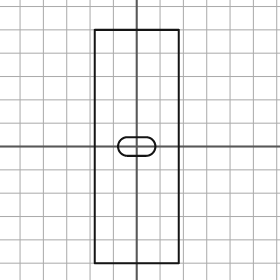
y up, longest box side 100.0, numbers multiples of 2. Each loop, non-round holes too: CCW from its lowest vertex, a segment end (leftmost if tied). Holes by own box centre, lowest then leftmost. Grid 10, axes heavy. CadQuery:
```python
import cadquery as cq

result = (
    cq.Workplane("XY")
    .moveTo(-18.0, -50.0)
    .lineTo(18.0, -50.0)
    .lineTo(18.0, 50.0)
    .lineTo(-18.0, 50.0)
    .close()
    .moveTo(-4.0, -4.0)
    .lineTo(4.0, -4.0)
    .threePointArc((8.0, 0.0), (4.0, 4.0))
    .lineTo(-4.0, 4.0)
    .threePointArc((-8.0, 0.0), (-4.0, -4.0))
    .close()
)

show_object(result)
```